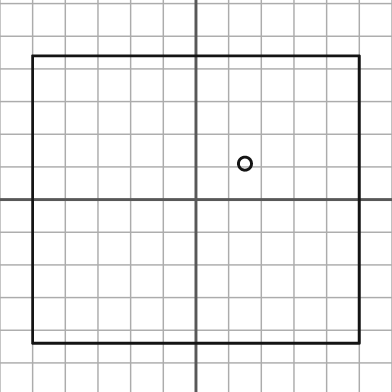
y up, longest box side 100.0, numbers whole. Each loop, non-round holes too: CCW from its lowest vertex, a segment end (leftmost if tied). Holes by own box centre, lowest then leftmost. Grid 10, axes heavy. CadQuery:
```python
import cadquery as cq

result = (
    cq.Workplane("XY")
    .moveTo(-50.0, -44.0)
    .lineTo(50.0, -44.0)
    .lineTo(50.0, 44.0)
    .lineTo(-50.0, 44.0)
    .close()
    .moveTo(15.0, 11.0)
    .circle(2.0)
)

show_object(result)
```